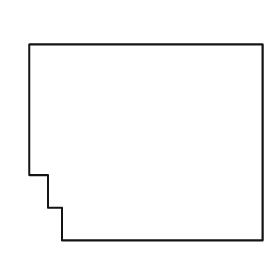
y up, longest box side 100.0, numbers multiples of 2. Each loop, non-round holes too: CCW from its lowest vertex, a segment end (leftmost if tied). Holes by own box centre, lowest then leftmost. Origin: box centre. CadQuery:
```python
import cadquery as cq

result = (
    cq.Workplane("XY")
    .moveTo(-36.0, -42.0)
    .lineTo(50.0, -42.0)
    .lineTo(50.0, 42.0)
    .lineTo(-50.0, 42.0)
    .lineTo(-50.0, -14.0)
    .lineTo(-42.0, -14.0)
    .lineTo(-42.0, -28.0)
    .lineTo(-36.0, -28.0)
    .close()
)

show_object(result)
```